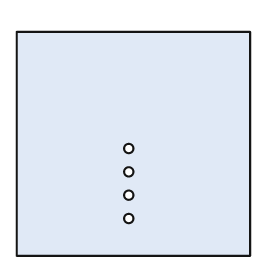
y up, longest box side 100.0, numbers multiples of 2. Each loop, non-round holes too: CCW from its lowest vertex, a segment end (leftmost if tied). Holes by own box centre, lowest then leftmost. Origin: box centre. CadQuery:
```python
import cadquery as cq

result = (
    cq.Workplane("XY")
    .moveTo(-50.0, -48.0)
    .lineTo(50.0, -48.0)
    .lineTo(50.0, 48.0)
    .lineTo(-50.0, 48.0)
    .close()
    .moveTo(-2.0, -32.0)
    .circle(2.0)
    .moveTo(-2.0, -22.0)
    .circle(2.0)
    .moveTo(-2.0, -12.0)
    .circle(2.0)
    .moveTo(-2.0, -2.0)
    .circle(2.0)
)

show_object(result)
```